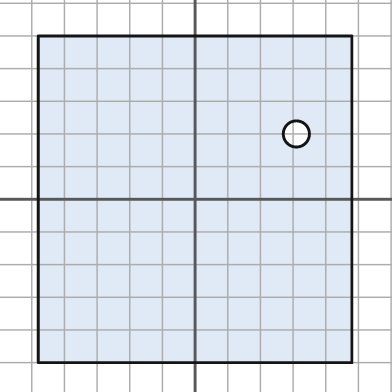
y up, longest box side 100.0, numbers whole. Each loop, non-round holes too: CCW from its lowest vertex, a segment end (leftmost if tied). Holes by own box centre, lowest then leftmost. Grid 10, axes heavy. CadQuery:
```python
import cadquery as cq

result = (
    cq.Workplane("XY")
    .moveTo(-48.0, -50.0)
    .lineTo(48.0, -50.0)
    .lineTo(48.0, 50.0)
    .lineTo(-48.0, 50.0)
    .close()
    .moveTo(31.0, 20.0)
    .circle(4.0)
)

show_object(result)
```